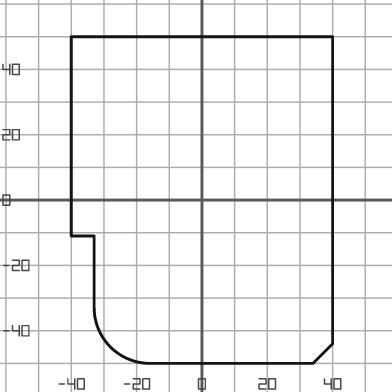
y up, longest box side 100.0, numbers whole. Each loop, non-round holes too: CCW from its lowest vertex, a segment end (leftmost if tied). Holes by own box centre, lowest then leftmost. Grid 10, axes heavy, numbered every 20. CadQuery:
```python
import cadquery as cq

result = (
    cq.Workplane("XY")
    .moveTo(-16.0, -50.0)
    .lineTo(34.0, -50.0)
    .lineTo(40.0, -44.0)
    .lineTo(40.0, 50.0)
    .lineTo(-40.0, 50.0)
    .lineTo(-40.0, -11.0)
    .lineTo(-33.0, -11.0)
    .lineTo(-33.0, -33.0)
    .threePointArc((-28.0, -45.0), (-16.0, -50.0))
    .close()
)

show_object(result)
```